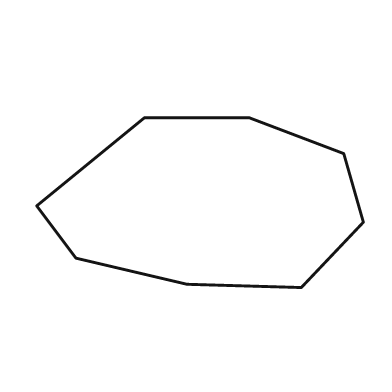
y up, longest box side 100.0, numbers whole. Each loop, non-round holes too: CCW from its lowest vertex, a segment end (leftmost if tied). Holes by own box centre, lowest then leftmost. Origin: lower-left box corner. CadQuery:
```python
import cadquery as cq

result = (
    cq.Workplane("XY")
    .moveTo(81.0, 0.0)
    .lineTo(100.0, 20.0)
    .lineTo(94.0, 41.0)
    .lineTo(65.0, 52.0)
    .lineTo(33.0, 52.0)
    .lineTo(0.0, 25.0)
    .lineTo(12.0, 9.0)
    .lineTo(46.0, 1.0)
    .close()
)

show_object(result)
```